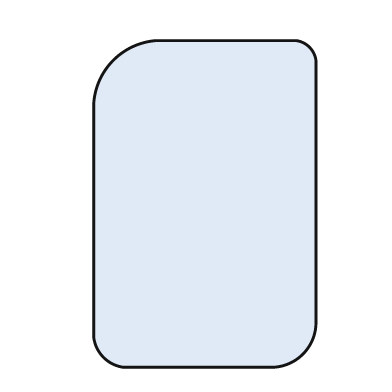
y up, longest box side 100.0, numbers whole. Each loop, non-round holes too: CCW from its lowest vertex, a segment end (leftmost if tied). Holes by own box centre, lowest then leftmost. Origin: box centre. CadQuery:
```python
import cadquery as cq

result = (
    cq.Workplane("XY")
    .moveTo(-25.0, -50.0)
    .lineTo(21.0, -50.0)
    .threePointArc((30.0, -46.0), (34.0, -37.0))
    .lineTo(34.0, 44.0)
    .threePointArc((32.0, 48.0), (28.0, 50.0))
    .lineTo(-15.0, 50.0)
    .threePointArc((-28.0, 44.0), (-34.0, 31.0))
    .lineTo(-34.0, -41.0)
    .threePointArc((-31.0, -47.0), (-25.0, -50.0))
    .close()
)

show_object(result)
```